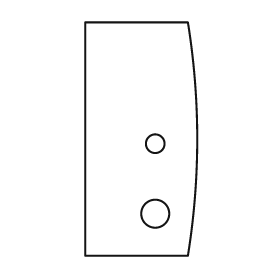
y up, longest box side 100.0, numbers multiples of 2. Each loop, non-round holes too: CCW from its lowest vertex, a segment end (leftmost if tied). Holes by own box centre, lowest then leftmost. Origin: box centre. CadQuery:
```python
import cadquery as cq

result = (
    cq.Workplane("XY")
    .moveTo(-24.0, -50.0)
    .lineTo(20.0, -50.0)
    .threePointArc((24.0, 0.0), (20.0, 50.0))
    .lineTo(-24.0, 50.0)
    .close()
    .moveTo(6.0, -32.0)
    .circle(6.0)
    .moveTo(6.0, -2.0)
    .circle(4.0)
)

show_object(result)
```